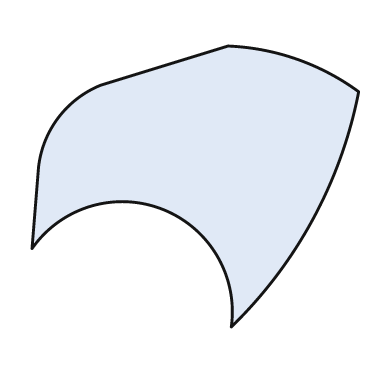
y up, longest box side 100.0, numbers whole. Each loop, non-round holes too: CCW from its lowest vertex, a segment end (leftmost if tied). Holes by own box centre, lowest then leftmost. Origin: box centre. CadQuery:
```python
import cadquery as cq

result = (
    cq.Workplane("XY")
    .moveTo(11.0, -43.0)
    .threePointArc((36.0, -10.0), (50.0, 29.0))
    .threePointArc((31.0, 39.0), (10.0, 43.0))
    .lineTo(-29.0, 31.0)
    .threePointArc((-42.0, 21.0), (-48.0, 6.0))
    .lineTo(-50.0, -19.0)
    .threePointArc((-10.0, -7.0), (11.0, -43.0))
    .close()
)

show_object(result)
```